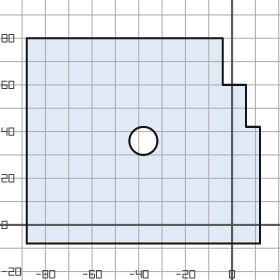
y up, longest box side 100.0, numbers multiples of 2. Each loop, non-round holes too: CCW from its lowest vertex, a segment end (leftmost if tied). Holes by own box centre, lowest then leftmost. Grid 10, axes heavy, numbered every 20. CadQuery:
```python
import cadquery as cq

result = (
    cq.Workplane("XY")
    .moveTo(-88.0, -8.0)
    .lineTo(12.0, -8.0)
    .lineTo(12.0, 42.0)
    .lineTo(6.0, 42.0)
    .lineTo(6.0, 60.0)
    .lineTo(-4.0, 60.0)
    .lineTo(-4.0, 80.0)
    .lineTo(-88.0, 80.0)
    .close()
    .moveTo(-38.0, 36.0)
    .circle(6.0)
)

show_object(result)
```